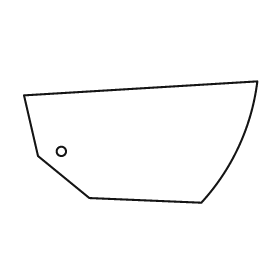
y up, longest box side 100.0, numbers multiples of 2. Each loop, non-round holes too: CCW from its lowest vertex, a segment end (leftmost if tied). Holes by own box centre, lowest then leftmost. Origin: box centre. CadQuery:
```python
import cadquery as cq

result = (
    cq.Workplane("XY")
    .moveTo(26.0, -26.0)
    .threePointArc((42.0, -2.0), (50.0, 26.0))
    .lineTo(-50.0, 20.0)
    .lineTo(-44.0, -6.0)
    .lineTo(-22.0, -24.0)
    .close()
    .moveTo(-34.0, -4.0)
    .circle(2.0)
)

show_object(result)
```